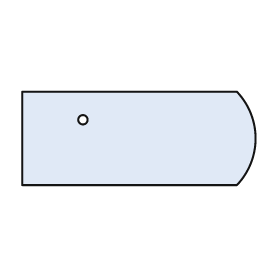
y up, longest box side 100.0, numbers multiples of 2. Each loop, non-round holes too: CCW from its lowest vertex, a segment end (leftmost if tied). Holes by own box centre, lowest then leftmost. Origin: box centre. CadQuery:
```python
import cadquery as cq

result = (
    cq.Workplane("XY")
    .moveTo(-50.0, -20.0)
    .lineTo(42.0, -20.0)
    .threePointArc((50.0, 0.0), (42.0, 20.0))
    .lineTo(-50.0, 20.0)
    .close()
    .moveTo(-24.0, 8.0)
    .circle(2.0)
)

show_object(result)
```